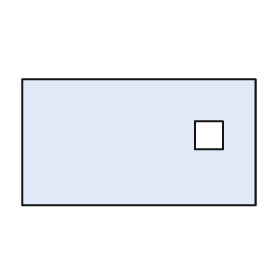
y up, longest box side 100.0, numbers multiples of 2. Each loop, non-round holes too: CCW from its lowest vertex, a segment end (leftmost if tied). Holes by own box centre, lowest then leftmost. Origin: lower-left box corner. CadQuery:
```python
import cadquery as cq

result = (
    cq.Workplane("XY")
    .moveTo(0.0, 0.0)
    .lineTo(100.0, 0.0)
    .lineTo(100.0, 54.0)
    .lineTo(0.0, 54.0)
    .close()
    .moveTo(74.0, 24.0)
    .lineTo(86.0, 24.0)
    .lineTo(86.0, 36.0)
    .lineTo(74.0, 36.0)
    .close()
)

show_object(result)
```